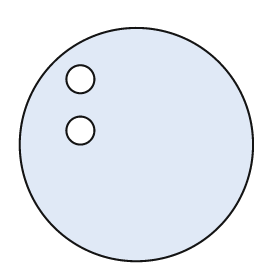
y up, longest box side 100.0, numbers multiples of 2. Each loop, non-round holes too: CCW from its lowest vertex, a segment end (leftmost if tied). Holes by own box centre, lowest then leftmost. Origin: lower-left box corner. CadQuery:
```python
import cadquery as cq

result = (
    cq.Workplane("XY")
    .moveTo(50.0, 50.0)
    .circle(50.0)
    .moveTo(26.0, 56.0)
    .circle(6.0)
    .moveTo(26.0, 78.0)
    .circle(6.0)
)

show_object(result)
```